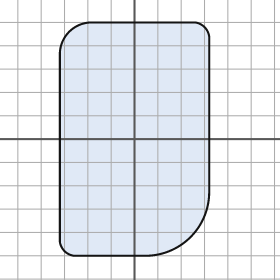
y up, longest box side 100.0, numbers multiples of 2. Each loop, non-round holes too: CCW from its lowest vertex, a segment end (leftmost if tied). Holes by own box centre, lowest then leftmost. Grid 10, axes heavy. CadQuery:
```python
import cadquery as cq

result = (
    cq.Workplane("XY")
    .moveTo(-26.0, -50.0)
    .lineTo(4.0, -50.0)
    .threePointArc((24.0, -42.0), (32.0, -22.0))
    .lineTo(32.0, 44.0)
    .threePointArc((30.0, 48.0), (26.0, 50.0))
    .lineTo(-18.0, 50.0)
    .threePointArc((-28.0, 46.0), (-32.0, 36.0))
    .lineTo(-32.0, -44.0)
    .threePointArc((-30.0, -48.0), (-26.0, -50.0))
    .close()
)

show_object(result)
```